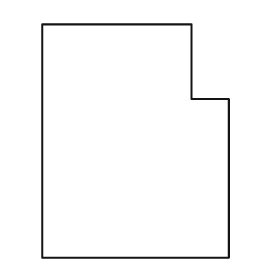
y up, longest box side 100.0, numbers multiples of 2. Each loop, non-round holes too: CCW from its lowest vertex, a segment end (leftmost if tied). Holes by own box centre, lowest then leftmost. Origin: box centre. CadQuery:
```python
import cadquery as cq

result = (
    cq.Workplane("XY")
    .moveTo(-40.0, -50.0)
    .lineTo(40.0, -50.0)
    .lineTo(40.0, 18.0)
    .lineTo(24.0, 18.0)
    .lineTo(24.0, 50.0)
    .lineTo(-40.0, 50.0)
    .close()
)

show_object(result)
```